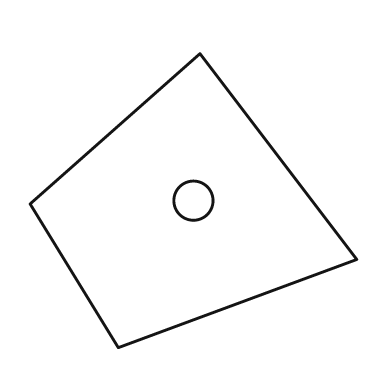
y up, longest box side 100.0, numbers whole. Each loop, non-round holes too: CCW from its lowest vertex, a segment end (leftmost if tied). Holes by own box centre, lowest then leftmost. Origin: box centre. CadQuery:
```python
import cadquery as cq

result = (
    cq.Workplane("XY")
    .moveTo(-23.0, -45.0)
    .lineTo(50.0, -18.0)
    .lineTo(2.0, 45.0)
    .lineTo(-50.0, -1.0)
    .close()
    .moveTo(0.0, 0.0)
    .circle(6.0)
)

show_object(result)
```